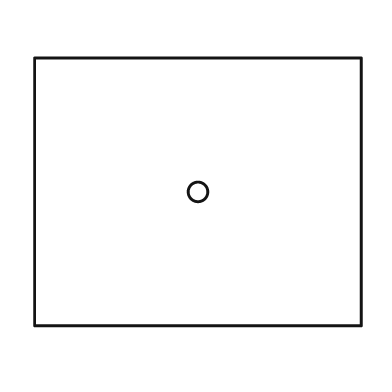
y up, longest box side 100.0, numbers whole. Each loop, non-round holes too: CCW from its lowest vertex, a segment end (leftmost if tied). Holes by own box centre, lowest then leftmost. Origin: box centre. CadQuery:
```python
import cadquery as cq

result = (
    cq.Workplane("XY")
    .moveTo(-50.0, -41.0)
    .lineTo(50.0, -41.0)
    .lineTo(50.0, 41.0)
    .lineTo(-50.0, 41.0)
    .close()
    .moveTo(0.0, 0.0)
    .circle(3.0)
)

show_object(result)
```